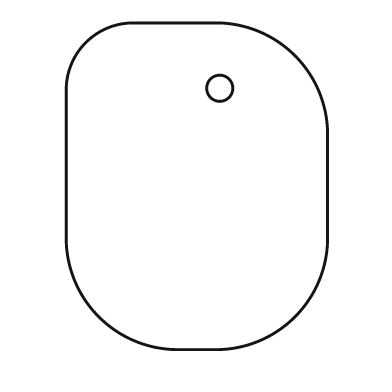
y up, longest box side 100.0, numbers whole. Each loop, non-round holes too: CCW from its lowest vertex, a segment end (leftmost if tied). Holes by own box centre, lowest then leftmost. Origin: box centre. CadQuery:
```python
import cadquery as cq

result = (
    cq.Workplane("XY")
    .moveTo(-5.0, -50.0)
    .lineTo(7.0, -50.0)
    .threePointArc((30.0, -40.0), (40.0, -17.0))
    .lineTo(40.0, 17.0)
    .threePointArc((30.0, 40.0), (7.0, 50.0))
    .lineTo(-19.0, 50.0)
    .threePointArc((-34.0, 44.0), (-40.0, 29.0))
    .lineTo(-40.0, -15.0)
    .threePointArc((-30.0, -40.0), (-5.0, -50.0))
    .close()
    .moveTo(7.0, 30.0)
    .circle(4.0)
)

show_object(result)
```